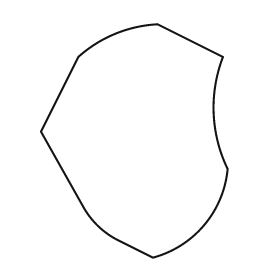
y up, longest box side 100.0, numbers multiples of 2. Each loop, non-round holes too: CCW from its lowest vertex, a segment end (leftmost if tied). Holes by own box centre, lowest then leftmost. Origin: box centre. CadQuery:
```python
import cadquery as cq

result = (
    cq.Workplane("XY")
    .moveTo(8.0, -50.0)
    .threePointArc((30.0, -36.0), (40.0, -12.0))
    .threePointArc((34.0, 12.0), (38.0, 36.0))
    .lineTo(10.0, 50.0)
    .threePointArc((-8.0, 46.0), (-24.0, 36.0))
    .lineTo(-40.0, 4.0)
    .lineTo(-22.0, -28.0)
    .threePointArc((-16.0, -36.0), (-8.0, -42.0))
    .close()
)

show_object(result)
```